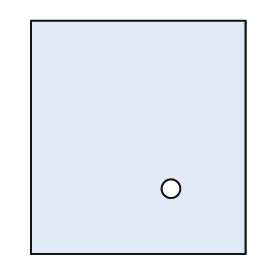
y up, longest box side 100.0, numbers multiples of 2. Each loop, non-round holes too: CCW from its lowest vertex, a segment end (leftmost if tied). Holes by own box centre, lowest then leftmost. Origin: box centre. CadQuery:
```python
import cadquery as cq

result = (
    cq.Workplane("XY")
    .moveTo(-46.0, -50.0)
    .lineTo(46.0, -50.0)
    .lineTo(46.0, 50.0)
    .lineTo(-46.0, 50.0)
    .close()
    .moveTo(14.0, -22.0)
    .circle(4.0)
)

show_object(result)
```